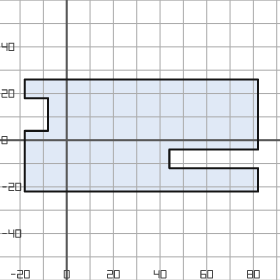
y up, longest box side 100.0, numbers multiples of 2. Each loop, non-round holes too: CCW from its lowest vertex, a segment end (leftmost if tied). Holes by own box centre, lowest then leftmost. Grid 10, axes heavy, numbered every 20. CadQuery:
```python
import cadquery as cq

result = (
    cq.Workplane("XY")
    .moveTo(-18.0, -22.0)
    .lineTo(82.0, -22.0)
    .lineTo(82.0, -12.0)
    .lineTo(44.0, -12.0)
    .lineTo(44.0, -4.0)
    .lineTo(82.0, -4.0)
    .lineTo(82.0, 26.0)
    .lineTo(-18.0, 26.0)
    .lineTo(-18.0, 18.0)
    .lineTo(-8.0, 18.0)
    .lineTo(-8.0, 4.0)
    .lineTo(-18.0, 4.0)
    .close()
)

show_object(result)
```